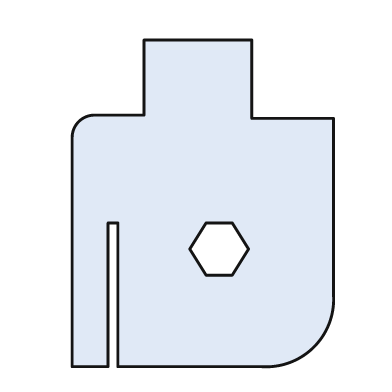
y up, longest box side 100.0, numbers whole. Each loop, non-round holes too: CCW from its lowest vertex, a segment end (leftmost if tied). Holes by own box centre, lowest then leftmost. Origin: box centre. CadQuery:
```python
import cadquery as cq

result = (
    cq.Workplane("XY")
    .moveTo(-40.0, -50.0)
    .lineTo(-29.0, -50.0)
    .lineTo(-29.0, -6.0)
    .lineTo(-26.0, -6.0)
    .lineTo(-26.0, -50.0)
    .lineTo(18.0, -50.0)
    .threePointArc((34.0, -44.0), (40.0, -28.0))
    .lineTo(40.0, 26.0)
    .lineTo(15.0, 26.0)
    .lineTo(15.0, 50.0)
    .lineTo(-18.0, 50.0)
    .lineTo(-18.0, 27.0)
    .lineTo(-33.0, 27.0)
    .threePointArc((-38.0, 25.0), (-40.0, 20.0))
    .close()
    .moveTo(1.0, -22.0)
    .lineTo(9.0, -22.0)
    .lineTo(14.0, -14.0)
    .lineTo(9.0, -6.0)
    .lineTo(1.0, -6.0)
    .lineTo(-4.0, -14.0)
    .close()
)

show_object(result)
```